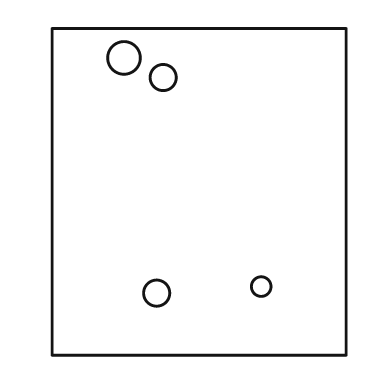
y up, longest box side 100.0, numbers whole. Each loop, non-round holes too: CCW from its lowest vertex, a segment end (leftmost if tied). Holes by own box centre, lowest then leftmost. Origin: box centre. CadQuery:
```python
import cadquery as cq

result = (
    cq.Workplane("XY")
    .moveTo(-45.0, -50.0)
    .lineTo(45.0, -50.0)
    .lineTo(45.0, 50.0)
    .lineTo(-45.0, 50.0)
    .close()
    .moveTo(-13.0, -31.0)
    .circle(4.0)
    .moveTo(19.0, -29.0)
    .circle(3.0)
    .moveTo(-11.0, 35.0)
    .circle(4.0)
    .moveTo(-23.0, 41.0)
    .circle(5.0)
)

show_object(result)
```